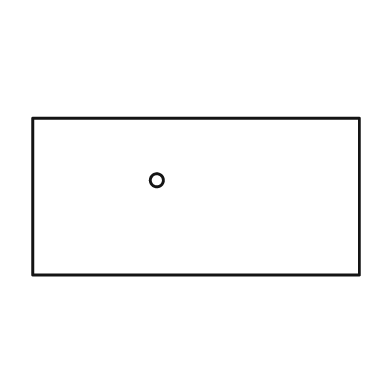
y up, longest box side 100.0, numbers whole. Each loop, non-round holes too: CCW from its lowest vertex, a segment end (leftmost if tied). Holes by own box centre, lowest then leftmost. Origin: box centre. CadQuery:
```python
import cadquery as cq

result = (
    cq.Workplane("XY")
    .moveTo(-50.0, -24.0)
    .lineTo(50.0, -24.0)
    .lineTo(50.0, 24.0)
    .lineTo(-50.0, 24.0)
    .close()
    .moveTo(-12.0, 5.0)
    .circle(2.0)
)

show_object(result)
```